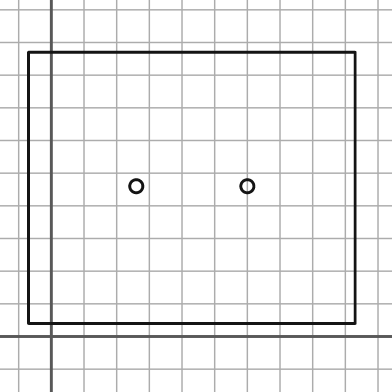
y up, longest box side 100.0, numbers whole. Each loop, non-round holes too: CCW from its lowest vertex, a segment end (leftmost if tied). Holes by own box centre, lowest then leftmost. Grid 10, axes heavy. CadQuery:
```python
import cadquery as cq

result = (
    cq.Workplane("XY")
    .moveTo(-7.0, 4.0)
    .lineTo(93.0, 4.0)
    .lineTo(93.0, 87.0)
    .lineTo(-7.0, 87.0)
    .close()
    .moveTo(26.0, 46.0)
    .circle(2.0)
    .moveTo(60.0, 46.0)
    .circle(2.0)
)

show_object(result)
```